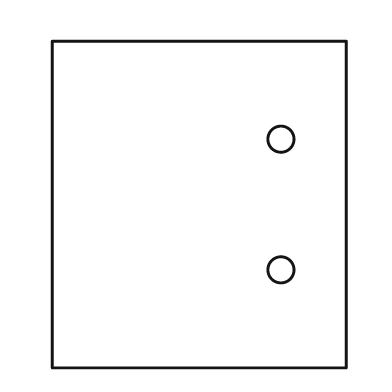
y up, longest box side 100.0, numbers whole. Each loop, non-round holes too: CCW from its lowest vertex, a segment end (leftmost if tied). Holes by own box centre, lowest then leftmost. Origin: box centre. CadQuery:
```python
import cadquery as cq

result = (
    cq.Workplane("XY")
    .moveTo(-45.0, -50.0)
    .lineTo(45.0, -50.0)
    .lineTo(45.0, 50.0)
    .lineTo(-45.0, 50.0)
    .close()
    .moveTo(25.0, -20.0)
    .circle(4.0)
    .moveTo(25.0, 20.0)
    .circle(4.0)
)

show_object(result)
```